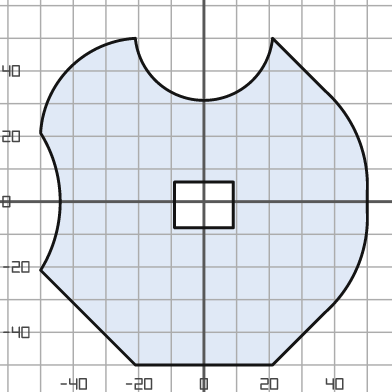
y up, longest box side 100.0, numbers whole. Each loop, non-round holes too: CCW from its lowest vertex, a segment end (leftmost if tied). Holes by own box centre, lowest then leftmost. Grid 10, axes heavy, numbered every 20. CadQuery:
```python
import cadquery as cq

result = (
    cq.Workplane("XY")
    .moveTo(-21.0, -50.0)
    .lineTo(21.0, -50.0)
    .lineTo(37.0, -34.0)
    .threePointArc((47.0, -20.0), (50.0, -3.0))
    .lineTo(50.0, 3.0)
    .threePointArc((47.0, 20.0), (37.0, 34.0))
    .lineTo(21.0, 50.0)
    .threePointArc((0.0, 31.0), (-21.0, 50.0))
    .threePointArc((-41.0, 41.0), (-50.0, 21.0))
    .threePointArc((-44.0, 0.0), (-50.0, -21.0))
    .close()
    .moveTo(-9.0, -8.0)
    .lineTo(9.0, -8.0)
    .lineTo(9.0, 6.0)
    .lineTo(-9.0, 6.0)
    .close()
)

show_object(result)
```